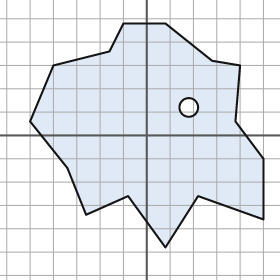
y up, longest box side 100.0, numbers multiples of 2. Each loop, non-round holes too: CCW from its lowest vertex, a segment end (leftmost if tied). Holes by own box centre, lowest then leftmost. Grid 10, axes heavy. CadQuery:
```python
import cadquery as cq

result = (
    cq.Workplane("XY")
    .moveTo(8.0, -48.0)
    .lineTo(22.0, -26.0)
    .lineTo(50.0, -36.0)
    .lineTo(50.0, -10.0)
    .lineTo(38.0, 6.0)
    .lineTo(40.0, 30.0)
    .lineTo(28.0, 32.0)
    .lineTo(8.0, 48.0)
    .lineTo(-10.0, 48.0)
    .lineTo(-16.0, 36.0)
    .lineTo(-40.0, 30.0)
    .lineTo(-50.0, 6.0)
    .lineTo(-34.0, -14.0)
    .lineTo(-26.0, -34.0)
    .lineTo(-8.0, -26.0)
    .close()
    .moveTo(18.0, 12.0)
    .circle(4.0)
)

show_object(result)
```